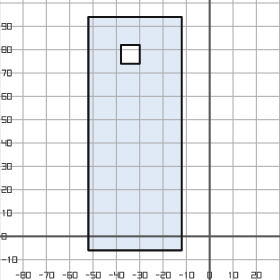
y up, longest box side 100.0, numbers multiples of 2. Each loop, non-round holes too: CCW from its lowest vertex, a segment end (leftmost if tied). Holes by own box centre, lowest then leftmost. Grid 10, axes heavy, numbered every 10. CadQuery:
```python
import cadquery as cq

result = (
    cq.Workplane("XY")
    .moveTo(-52.0, -6.0)
    .lineTo(-12.0, -6.0)
    .lineTo(-12.0, 94.0)
    .lineTo(-52.0, 94.0)
    .close()
    .moveTo(-38.0, 74.0)
    .lineTo(-30.0, 74.0)
    .lineTo(-30.0, 82.0)
    .lineTo(-38.0, 82.0)
    .close()
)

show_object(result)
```